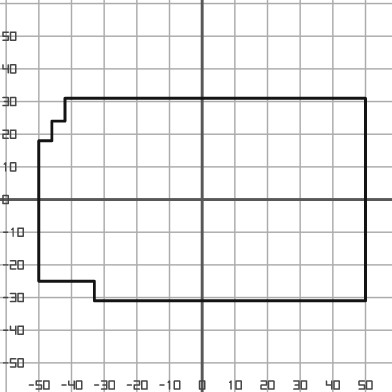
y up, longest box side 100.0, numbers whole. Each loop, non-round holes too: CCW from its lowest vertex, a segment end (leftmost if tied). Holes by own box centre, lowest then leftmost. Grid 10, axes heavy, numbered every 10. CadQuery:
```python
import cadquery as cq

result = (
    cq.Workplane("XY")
    .moveTo(-33.0, -31.0)
    .lineTo(50.0, -31.0)
    .lineTo(50.0, 31.0)
    .lineTo(-42.0, 31.0)
    .lineTo(-42.0, 24.0)
    .lineTo(-46.0, 24.0)
    .lineTo(-46.0, 18.0)
    .lineTo(-50.0, 18.0)
    .lineTo(-50.0, -25.0)
    .lineTo(-33.0, -25.0)
    .close()
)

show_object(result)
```